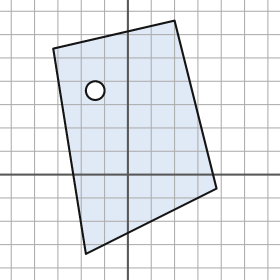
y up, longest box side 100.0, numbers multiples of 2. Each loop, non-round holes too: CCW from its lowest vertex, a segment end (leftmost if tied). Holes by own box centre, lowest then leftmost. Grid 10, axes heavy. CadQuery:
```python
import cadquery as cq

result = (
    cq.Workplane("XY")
    .moveTo(-18.0, -34.0)
    .lineTo(38.0, -6.0)
    .lineTo(20.0, 66.0)
    .lineTo(-32.0, 54.0)
    .close()
    .moveTo(-14.0, 36.0)
    .circle(4.0)
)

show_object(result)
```